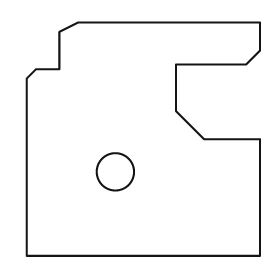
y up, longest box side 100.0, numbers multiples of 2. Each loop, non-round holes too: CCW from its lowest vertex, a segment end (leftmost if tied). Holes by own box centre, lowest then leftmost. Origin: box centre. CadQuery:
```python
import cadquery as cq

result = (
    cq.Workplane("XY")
    .moveTo(-50.0, -50.0)
    .lineTo(50.0, -50.0)
    .lineTo(50.0, 0.0)
    .lineTo(26.0, 0.0)
    .lineTo(14.0, 12.0)
    .lineTo(14.0, 32.0)
    .lineTo(44.0, 32.0)
    .lineTo(50.0, 38.0)
    .lineTo(50.0, 50.0)
    .lineTo(-28.0, 50.0)
    .lineTo(-36.0, 46.0)
    .lineTo(-36.0, 30.0)
    .lineTo(-46.0, 30.0)
    .lineTo(-50.0, 26.0)
    .close()
    .moveTo(-12.0, -14.0)
    .circle(8.0)
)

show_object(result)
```